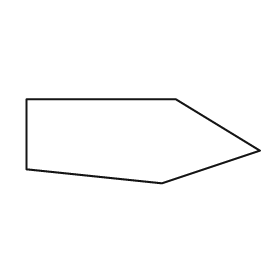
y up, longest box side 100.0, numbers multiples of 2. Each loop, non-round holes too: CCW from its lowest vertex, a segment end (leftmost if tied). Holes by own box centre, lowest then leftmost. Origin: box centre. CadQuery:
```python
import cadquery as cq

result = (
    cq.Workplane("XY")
    .moveTo(8.0, -18.0)
    .lineTo(50.0, -4.0)
    .lineTo(14.0, 18.0)
    .lineTo(-50.0, 18.0)
    .lineTo(-50.0, -12.0)
    .close()
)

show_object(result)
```